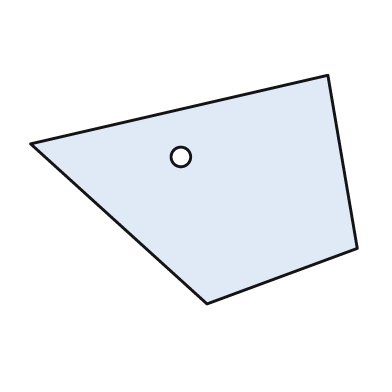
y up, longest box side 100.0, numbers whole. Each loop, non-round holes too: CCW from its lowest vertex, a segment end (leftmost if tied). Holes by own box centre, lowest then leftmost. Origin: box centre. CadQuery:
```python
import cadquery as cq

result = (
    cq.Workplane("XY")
    .moveTo(4.0, -35.0)
    .lineTo(50.0, -18.0)
    .lineTo(41.0, 35.0)
    .lineTo(-50.0, 14.0)
    .close()
    .moveTo(-4.0, 10.0)
    .circle(3.0)
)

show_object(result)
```